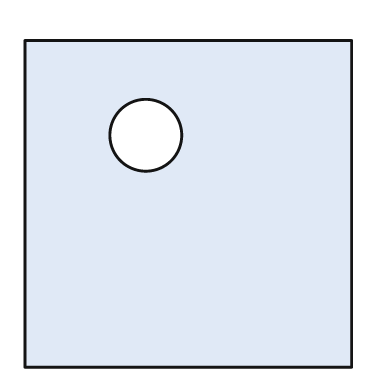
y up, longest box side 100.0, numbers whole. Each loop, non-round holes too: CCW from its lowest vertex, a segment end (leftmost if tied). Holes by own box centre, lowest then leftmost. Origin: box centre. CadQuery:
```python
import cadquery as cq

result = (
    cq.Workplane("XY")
    .moveTo(-50.0, -50.0)
    .lineTo(50.0, -50.0)
    .lineTo(50.0, 50.0)
    .lineTo(-50.0, 50.0)
    .close()
    .moveTo(-13.0, 21.0)
    .circle(11.0)
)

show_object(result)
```